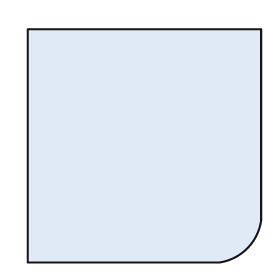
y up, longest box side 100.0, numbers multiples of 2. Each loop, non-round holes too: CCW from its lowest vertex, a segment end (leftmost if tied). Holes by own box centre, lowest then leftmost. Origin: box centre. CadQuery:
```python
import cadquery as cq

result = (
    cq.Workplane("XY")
    .moveTo(-50.0, -50.0)
    .lineTo(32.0, -50.0)
    .threePointArc((44.0, -44.0), (50.0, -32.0))
    .lineTo(50.0, 50.0)
    .lineTo(-50.0, 50.0)
    .close()
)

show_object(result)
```